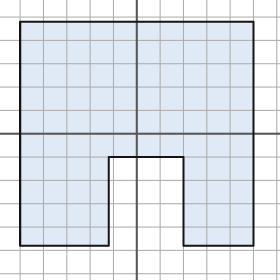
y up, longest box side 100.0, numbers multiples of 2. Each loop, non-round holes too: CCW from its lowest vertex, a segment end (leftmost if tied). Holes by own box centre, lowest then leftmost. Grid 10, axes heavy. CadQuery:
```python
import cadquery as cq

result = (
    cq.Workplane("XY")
    .moveTo(-50.0, -48.0)
    .lineTo(-12.0, -48.0)
    .lineTo(-12.0, -10.0)
    .lineTo(20.0, -10.0)
    .lineTo(20.0, -48.0)
    .lineTo(50.0, -48.0)
    .lineTo(50.0, 48.0)
    .lineTo(-50.0, 48.0)
    .close()
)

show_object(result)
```